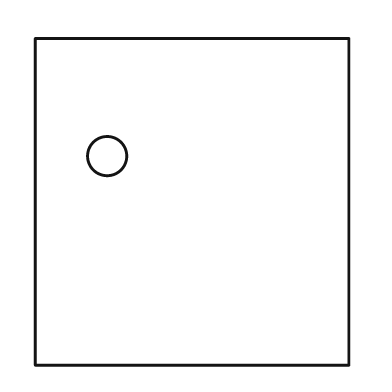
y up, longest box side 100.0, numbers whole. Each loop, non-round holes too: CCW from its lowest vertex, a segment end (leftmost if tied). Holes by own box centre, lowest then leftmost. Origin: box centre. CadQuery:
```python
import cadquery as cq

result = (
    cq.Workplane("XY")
    .moveTo(-48.0, -50.0)
    .lineTo(48.0, -50.0)
    .lineTo(48.0, 50.0)
    .lineTo(-48.0, 50.0)
    .close()
    .moveTo(-26.0, 14.0)
    .circle(6.0)
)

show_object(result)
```